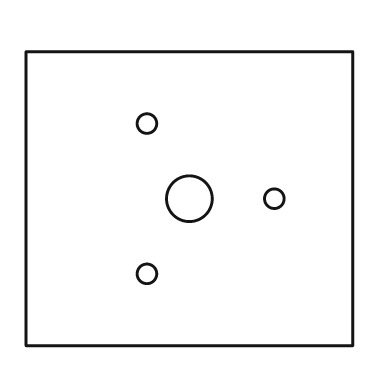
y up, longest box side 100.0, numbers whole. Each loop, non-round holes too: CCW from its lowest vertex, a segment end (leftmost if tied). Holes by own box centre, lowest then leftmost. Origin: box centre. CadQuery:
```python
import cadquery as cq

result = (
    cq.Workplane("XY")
    .moveTo(-50.0, -45.0)
    .lineTo(50.0, -45.0)
    .lineTo(50.0, 45.0)
    .lineTo(-50.0, 45.0)
    .close()
    .moveTo(-13.0, -23.0)
    .circle(3.0)
    .moveTo(0.0, 0.0)
    .circle(7.0)
    .moveTo(26.0, 0.0)
    .circle(3.0)
    .moveTo(-13.0, 23.0)
    .circle(3.0)
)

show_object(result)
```